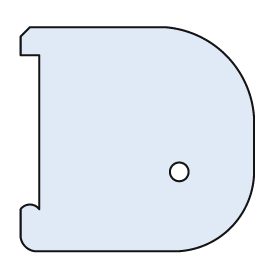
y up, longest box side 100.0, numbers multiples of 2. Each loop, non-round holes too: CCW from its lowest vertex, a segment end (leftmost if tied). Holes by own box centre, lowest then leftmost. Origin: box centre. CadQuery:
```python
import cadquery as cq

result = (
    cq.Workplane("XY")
    .moveTo(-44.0, -48.0)
    .lineTo(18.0, -48.0)
    .threePointArc((40.0, -38.0), (50.0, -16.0))
    .lineTo(50.0, 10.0)
    .threePointArc((38.0, 36.0), (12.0, 48.0))
    .lineTo(-46.0, 48.0)
    .lineTo(-50.0, 44.0)
    .lineTo(-50.0, 36.0)
    .lineTo(-42.0, 36.0)
    .lineTo(-42.0, -30.0)
    .threePointArc((-46.0, -28.0), (-50.0, -30.0))
    .lineTo(-50.0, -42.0)
    .threePointArc((-48.0, -46.0), (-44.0, -48.0))
    .close()
    .moveTo(18.0, -14.0)
    .circle(4.0)
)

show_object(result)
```